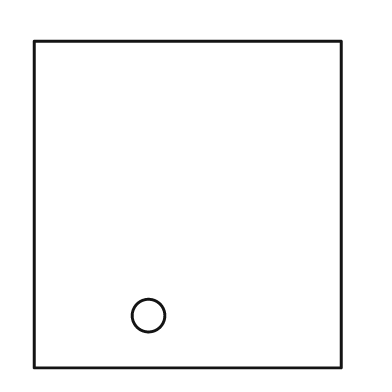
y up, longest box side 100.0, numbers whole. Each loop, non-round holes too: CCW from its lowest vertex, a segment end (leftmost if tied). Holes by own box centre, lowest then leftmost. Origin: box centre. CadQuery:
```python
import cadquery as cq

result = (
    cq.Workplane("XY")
    .moveTo(-47.0, -50.0)
    .lineTo(47.0, -50.0)
    .lineTo(47.0, 50.0)
    .lineTo(-47.0, 50.0)
    .close()
    .moveTo(-12.0, -34.0)
    .circle(5.0)
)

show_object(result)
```